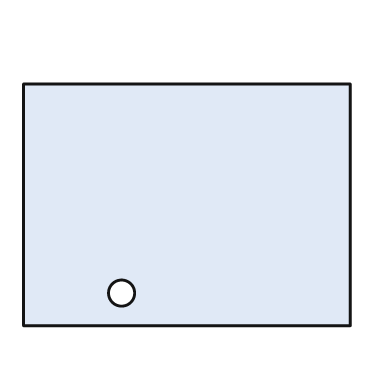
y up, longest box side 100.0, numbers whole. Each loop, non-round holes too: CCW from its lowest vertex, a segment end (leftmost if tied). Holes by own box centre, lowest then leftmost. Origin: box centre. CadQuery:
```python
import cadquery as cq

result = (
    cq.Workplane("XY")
    .moveTo(-50.0, -37.0)
    .lineTo(50.0, -37.0)
    .lineTo(50.0, 37.0)
    .lineTo(-50.0, 37.0)
    .close()
    .moveTo(-20.0, -27.0)
    .circle(4.0)
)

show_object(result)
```